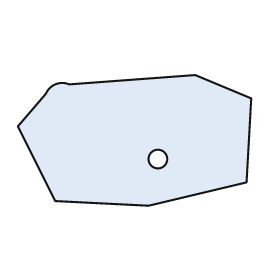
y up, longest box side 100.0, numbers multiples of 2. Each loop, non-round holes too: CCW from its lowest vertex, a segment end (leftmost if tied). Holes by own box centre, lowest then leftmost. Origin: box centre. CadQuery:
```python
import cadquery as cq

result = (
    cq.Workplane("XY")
    .moveTo(6.0, -28.0)
    .lineTo(48.0, -18.0)
    .lineTo(50.0, 18.0)
    .lineTo(26.0, 28.0)
    .lineTo(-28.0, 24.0)
    .threePointArc((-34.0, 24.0), (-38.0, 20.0))
    .lineTo(-50.0, 6.0)
    .lineTo(-34.0, -26.0)
    .close()
    .moveTo(10.0, -8.0)
    .circle(4.0)
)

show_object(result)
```